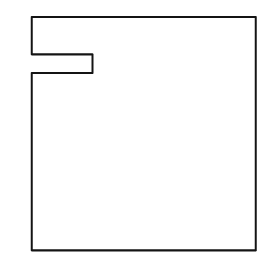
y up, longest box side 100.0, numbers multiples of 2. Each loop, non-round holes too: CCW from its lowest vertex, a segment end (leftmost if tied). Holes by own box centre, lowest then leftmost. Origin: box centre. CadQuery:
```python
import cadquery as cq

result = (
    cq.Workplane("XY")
    .moveTo(-48.0, -50.0)
    .lineTo(48.0, -50.0)
    .lineTo(48.0, 50.0)
    .lineTo(-48.0, 50.0)
    .lineTo(-48.0, 34.0)
    .lineTo(-22.0, 34.0)
    .lineTo(-22.0, 26.0)
    .lineTo(-48.0, 26.0)
    .close()
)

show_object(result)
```